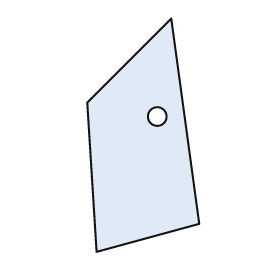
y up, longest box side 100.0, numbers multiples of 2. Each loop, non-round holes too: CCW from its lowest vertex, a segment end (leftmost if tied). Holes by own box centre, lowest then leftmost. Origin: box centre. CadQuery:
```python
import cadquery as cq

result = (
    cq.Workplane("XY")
    .moveTo(-20.0, -50.0)
    .lineTo(24.0, -38.0)
    .lineTo(12.0, 50.0)
    .lineTo(-24.0, 14.0)
    .close()
    .moveTo(6.0, 8.0)
    .circle(4.0)
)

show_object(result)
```